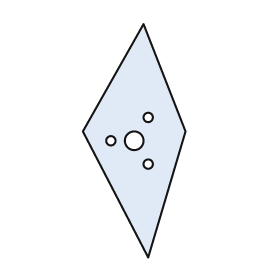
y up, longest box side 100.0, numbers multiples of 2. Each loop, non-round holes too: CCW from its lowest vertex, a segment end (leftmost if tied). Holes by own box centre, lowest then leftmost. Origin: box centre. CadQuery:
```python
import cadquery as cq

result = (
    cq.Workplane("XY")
    .moveTo(6.0, -50.0)
    .lineTo(22.0, 4.0)
    .lineTo(4.0, 50.0)
    .lineTo(-22.0, 4.0)
    .close()
    .moveTo(6.0, -10.0)
    .circle(2.0)
    .moveTo(-10.0, 0.0)
    .circle(2.0)
    .moveTo(0.0, 0.0)
    .circle(4.0)
    .moveTo(6.0, 10.0)
    .circle(2.0)
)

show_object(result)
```